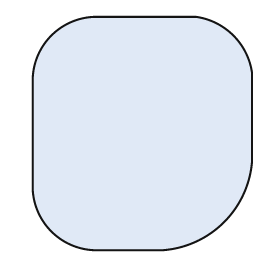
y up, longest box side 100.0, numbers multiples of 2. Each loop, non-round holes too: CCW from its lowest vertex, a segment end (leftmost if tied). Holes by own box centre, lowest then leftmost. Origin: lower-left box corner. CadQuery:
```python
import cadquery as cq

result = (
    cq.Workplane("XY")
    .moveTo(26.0, 0.0)
    .lineTo(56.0, 0.0)
    .threePointArc((82.0, 12.0), (94.0, 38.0))
    .lineTo(94.0, 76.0)
    .threePointArc((86.0, 92.0), (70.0, 100.0))
    .lineTo(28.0, 100.0)
    .threePointArc((8.0, 92.0), (0.0, 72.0))
    .lineTo(0.0, 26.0)
    .threePointArc((8.0, 8.0), (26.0, 0.0))
    .close()
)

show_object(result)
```